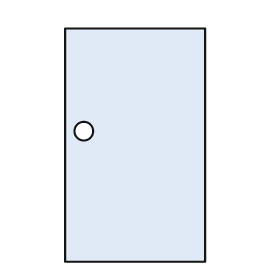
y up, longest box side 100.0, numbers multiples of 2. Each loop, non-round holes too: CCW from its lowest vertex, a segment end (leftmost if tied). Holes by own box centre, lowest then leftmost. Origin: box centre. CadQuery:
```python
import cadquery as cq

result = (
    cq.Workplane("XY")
    .moveTo(-30.0, -50.0)
    .lineTo(30.0, -50.0)
    .lineTo(30.0, 50.0)
    .lineTo(-30.0, 50.0)
    .close()
    .moveTo(-22.0, 6.0)
    .circle(4.0)
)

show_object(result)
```